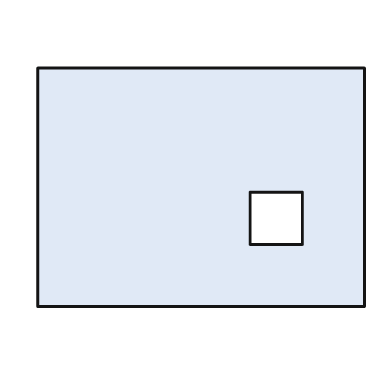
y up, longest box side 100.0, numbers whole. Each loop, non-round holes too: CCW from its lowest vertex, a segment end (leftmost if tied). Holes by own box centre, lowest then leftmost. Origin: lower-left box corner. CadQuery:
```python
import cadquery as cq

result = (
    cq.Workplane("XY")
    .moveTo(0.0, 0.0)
    .lineTo(100.0, 0.0)
    .lineTo(100.0, 73.0)
    .lineTo(0.0, 73.0)
    .close()
    .moveTo(65.0, 19.0)
    .lineTo(81.0, 19.0)
    .lineTo(81.0, 35.0)
    .lineTo(65.0, 35.0)
    .close()
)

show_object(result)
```